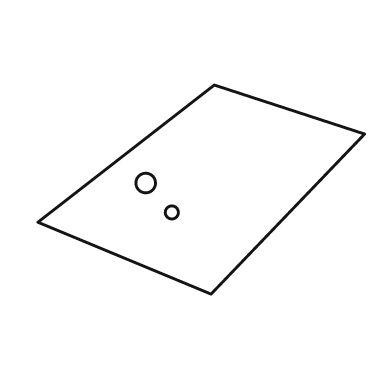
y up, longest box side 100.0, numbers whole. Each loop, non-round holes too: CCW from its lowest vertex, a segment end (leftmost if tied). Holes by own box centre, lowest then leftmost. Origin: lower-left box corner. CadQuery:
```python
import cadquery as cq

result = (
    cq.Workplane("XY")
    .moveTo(53.0, 0.0)
    .lineTo(100.0, 49.0)
    .lineTo(54.0, 64.0)
    .lineTo(0.0, 22.0)
    .close()
    .moveTo(41.0, 25.0)
    .circle(2.0)
    .moveTo(33.0, 34.0)
    .circle(3.0)
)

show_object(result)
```